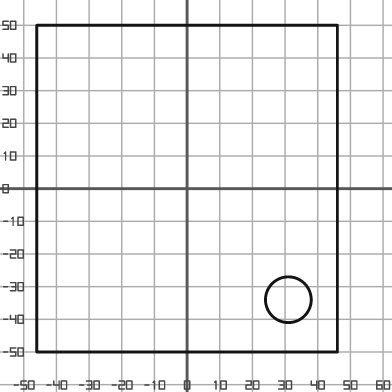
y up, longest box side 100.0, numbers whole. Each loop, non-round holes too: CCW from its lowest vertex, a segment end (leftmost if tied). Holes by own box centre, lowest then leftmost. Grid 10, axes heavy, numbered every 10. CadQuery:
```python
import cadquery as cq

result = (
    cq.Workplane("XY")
    .moveTo(-46.0, -50.0)
    .lineTo(46.0, -50.0)
    .lineTo(46.0, 50.0)
    .lineTo(-46.0, 50.0)
    .close()
    .moveTo(31.0, -34.0)
    .circle(7.0)
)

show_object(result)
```